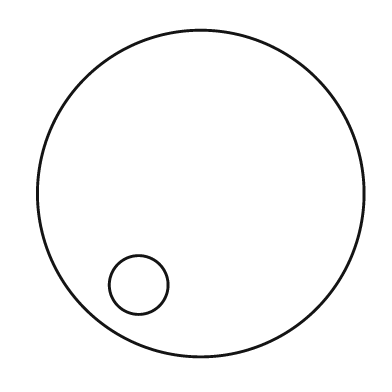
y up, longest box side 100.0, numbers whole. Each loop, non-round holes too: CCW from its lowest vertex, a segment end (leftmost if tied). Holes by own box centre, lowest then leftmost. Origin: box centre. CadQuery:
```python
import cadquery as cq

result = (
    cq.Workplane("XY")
    .moveTo(0.0, 0.0)
    .circle(50.0)
    .moveTo(-19.0, -28.0)
    .circle(9.0)
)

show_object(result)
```